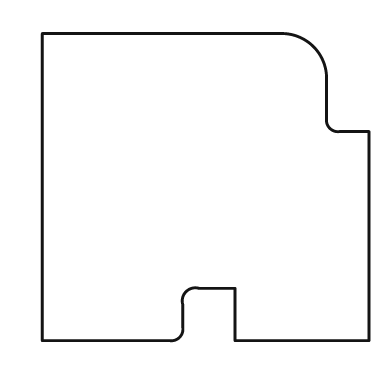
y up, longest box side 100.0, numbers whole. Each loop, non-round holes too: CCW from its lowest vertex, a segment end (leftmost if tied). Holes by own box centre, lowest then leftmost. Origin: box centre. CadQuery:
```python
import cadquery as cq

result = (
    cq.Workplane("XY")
    .moveTo(-50.0, -47.0)
    .lineTo(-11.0, -47.0)
    .threePointArc((-8.0, -46.0), (-7.0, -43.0))
    .lineTo(-7.0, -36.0)
    .threePointArc((-6.0, -32.0), (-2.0, -31.0))
    .lineTo(9.0, -31.0)
    .lineTo(9.0, -47.0)
    .lineTo(50.0, -47.0)
    .lineTo(50.0, 17.0)
    .lineTo(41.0, 17.0)
    .threePointArc((38.0, 18.0), (37.0, 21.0))
    .lineTo(37.0, 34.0)
    .threePointArc((33.0, 43.0), (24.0, 47.0))
    .lineTo(-50.0, 47.0)
    .close()
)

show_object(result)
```